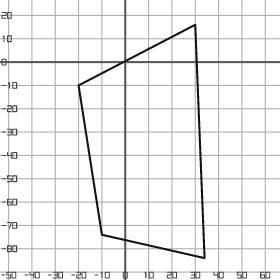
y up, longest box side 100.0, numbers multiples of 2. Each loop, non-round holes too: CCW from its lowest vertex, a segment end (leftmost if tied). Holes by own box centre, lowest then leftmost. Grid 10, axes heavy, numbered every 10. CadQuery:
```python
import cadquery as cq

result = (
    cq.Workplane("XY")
    .moveTo(34.0, -84.0)
    .lineTo(30.0, 16.0)
    .lineTo(-20.0, -10.0)
    .lineTo(-10.0, -74.0)
    .close()
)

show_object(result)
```